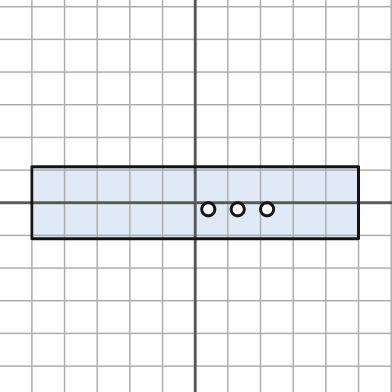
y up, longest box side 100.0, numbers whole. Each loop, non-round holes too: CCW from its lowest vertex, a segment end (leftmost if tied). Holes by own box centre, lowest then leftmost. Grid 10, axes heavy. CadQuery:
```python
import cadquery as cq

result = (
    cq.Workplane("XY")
    .moveTo(-50.0, -11.0)
    .lineTo(50.0, -11.0)
    .lineTo(50.0, 11.0)
    .lineTo(-50.0, 11.0)
    .close()
    .moveTo(4.0, -2.0)
    .circle(2.0)
    .moveTo(13.0, -2.0)
    .circle(2.0)
    .moveTo(22.0, -2.0)
    .circle(2.0)
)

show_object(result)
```